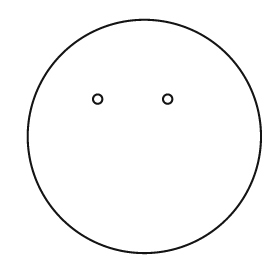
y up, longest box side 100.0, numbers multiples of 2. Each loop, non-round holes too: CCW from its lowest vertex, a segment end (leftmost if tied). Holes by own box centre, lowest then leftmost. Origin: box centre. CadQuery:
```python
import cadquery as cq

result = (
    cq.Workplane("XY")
    .moveTo(0.0, 0.0)
    .circle(50.0)
    .moveTo(-20.0, 16.0)
    .circle(2.0)
    .moveTo(10.0, 16.0)
    .circle(2.0)
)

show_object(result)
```